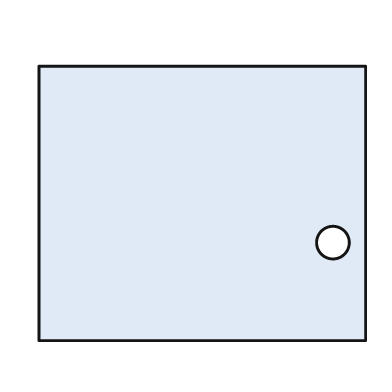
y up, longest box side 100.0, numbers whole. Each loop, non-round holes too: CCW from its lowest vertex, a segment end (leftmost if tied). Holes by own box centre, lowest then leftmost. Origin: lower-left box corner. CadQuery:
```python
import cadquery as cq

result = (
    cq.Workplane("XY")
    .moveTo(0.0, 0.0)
    .lineTo(100.0, 0.0)
    .lineTo(100.0, 84.0)
    .lineTo(0.0, 84.0)
    .close()
    .moveTo(90.0, 30.0)
    .circle(5.0)
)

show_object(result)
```